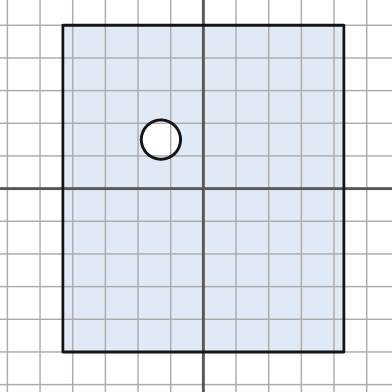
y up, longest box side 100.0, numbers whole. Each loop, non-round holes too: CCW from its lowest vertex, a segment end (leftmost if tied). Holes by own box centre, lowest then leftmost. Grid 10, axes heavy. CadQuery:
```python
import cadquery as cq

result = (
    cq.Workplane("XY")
    .moveTo(-43.0, -50.0)
    .lineTo(43.0, -50.0)
    .lineTo(43.0, 50.0)
    .lineTo(-43.0, 50.0)
    .close()
    .moveTo(-13.0, 15.0)
    .circle(6.0)
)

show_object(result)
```